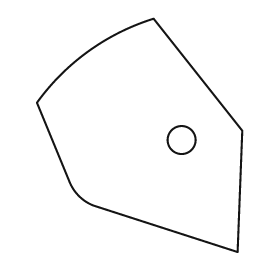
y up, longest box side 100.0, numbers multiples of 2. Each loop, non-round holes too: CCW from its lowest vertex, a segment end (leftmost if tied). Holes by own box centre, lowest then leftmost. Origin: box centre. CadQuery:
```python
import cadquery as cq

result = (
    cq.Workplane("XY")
    .moveTo(42.0, -50.0)
    .lineTo(44.0, 2.0)
    .lineTo(6.0, 50.0)
    .threePointArc((-22.0, 36.0), (-44.0, 14.0))
    .lineTo(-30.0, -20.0)
    .threePointArc((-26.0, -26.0), (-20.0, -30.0))
    .close()
    .moveTo(18.0, -2.0)
    .circle(6.0)
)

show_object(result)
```